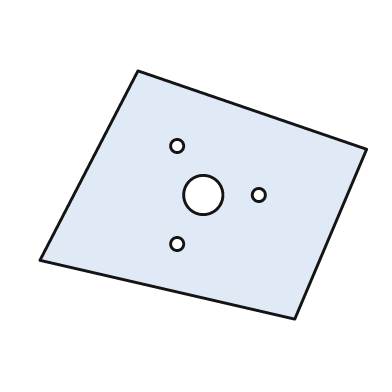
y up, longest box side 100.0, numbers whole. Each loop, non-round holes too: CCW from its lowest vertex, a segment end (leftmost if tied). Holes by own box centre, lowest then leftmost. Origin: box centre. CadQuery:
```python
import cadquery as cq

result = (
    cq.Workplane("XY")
    .moveTo(28.0, -38.0)
    .lineTo(50.0, 14.0)
    .lineTo(-20.0, 38.0)
    .lineTo(-50.0, -20.0)
    .close()
    .moveTo(-8.0, -15.0)
    .circle(2.0)
    .moveTo(0.0, 0.0)
    .circle(6.0)
    .moveTo(17.0, 0.0)
    .circle(2.0)
    .moveTo(-8.0, 15.0)
    .circle(2.0)
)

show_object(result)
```